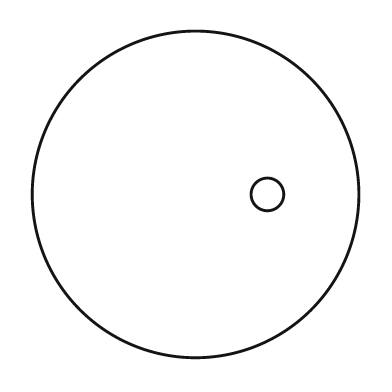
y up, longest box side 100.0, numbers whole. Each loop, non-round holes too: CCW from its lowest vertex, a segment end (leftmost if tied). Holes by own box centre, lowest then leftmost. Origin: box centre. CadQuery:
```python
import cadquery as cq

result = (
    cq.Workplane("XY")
    .moveTo(0.0, 0.0)
    .circle(50.0)
    .moveTo(22.0, 0.0)
    .circle(5.0)
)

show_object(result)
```